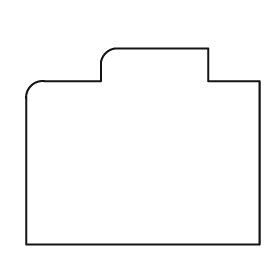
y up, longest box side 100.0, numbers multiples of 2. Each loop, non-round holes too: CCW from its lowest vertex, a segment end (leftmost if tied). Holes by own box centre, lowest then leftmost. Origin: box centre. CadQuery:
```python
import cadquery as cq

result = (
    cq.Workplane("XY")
    .moveTo(-50.0, -42.0)
    .lineTo(50.0, -42.0)
    .lineTo(50.0, 28.0)
    .lineTo(28.0, 28.0)
    .lineTo(28.0, 42.0)
    .lineTo(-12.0, 42.0)
    .threePointArc((-16.0, 40.0), (-18.0, 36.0))
    .lineTo(-18.0, 28.0)
    .lineTo(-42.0, 28.0)
    .threePointArc((-48.0, 26.0), (-50.0, 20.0))
    .close()
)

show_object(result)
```